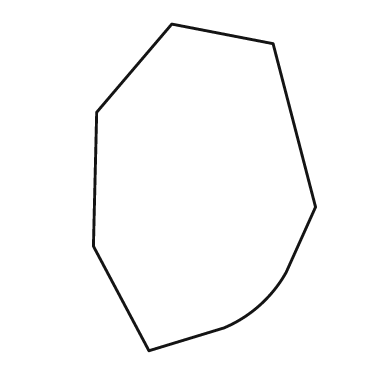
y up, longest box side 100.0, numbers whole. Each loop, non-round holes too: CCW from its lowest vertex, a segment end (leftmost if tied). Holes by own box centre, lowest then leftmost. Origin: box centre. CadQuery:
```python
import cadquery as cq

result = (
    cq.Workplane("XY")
    .moveTo(-17.0, -50.0)
    .lineTo(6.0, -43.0)
    .threePointArc((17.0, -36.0), (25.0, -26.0))
    .lineTo(34.0, -6.0)
    .lineTo(21.0, 44.0)
    .lineTo(-10.0, 50.0)
    .lineTo(-33.0, 23.0)
    .lineTo(-34.0, -18.0)
    .close()
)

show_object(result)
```